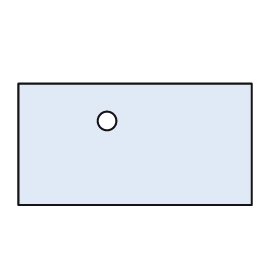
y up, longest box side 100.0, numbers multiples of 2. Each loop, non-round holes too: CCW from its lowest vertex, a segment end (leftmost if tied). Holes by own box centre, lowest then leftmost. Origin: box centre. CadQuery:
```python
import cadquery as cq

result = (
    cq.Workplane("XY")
    .moveTo(-50.0, -26.0)
    .lineTo(50.0, -26.0)
    .lineTo(50.0, 26.0)
    .lineTo(-50.0, 26.0)
    .close()
    .moveTo(-12.0, 10.0)
    .circle(4.0)
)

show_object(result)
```